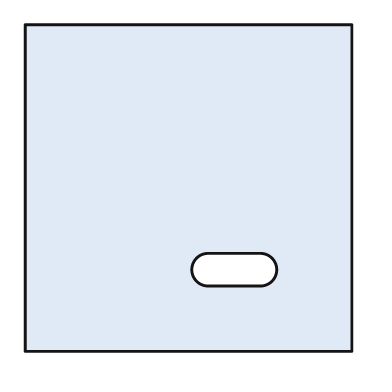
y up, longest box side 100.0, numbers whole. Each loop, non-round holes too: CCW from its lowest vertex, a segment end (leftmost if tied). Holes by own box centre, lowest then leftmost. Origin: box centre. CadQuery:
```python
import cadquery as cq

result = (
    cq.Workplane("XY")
    .moveTo(-50.0, -50.0)
    .lineTo(50.0, -50.0)
    .lineTo(50.0, 50.0)
    .lineTo(-50.0, 50.0)
    .close()
    .moveTo(6.0, -30.0)
    .lineTo(22.0, -30.0)
    .threePointArc((27.0, -25.0), (22.0, -20.0))
    .lineTo(6.0, -20.0)
    .threePointArc((1.0, -25.0), (6.0, -30.0))
    .close()
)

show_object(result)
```